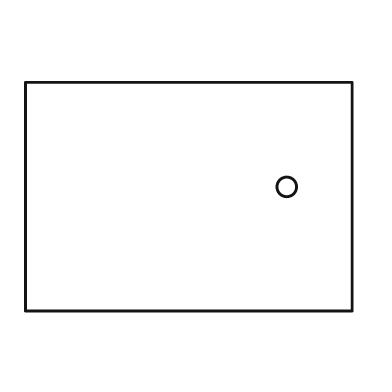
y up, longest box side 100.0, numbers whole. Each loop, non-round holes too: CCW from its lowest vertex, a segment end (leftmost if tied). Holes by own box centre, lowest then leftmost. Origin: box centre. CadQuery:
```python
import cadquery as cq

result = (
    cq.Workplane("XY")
    .moveTo(-50.0, -35.0)
    .lineTo(50.0, -35.0)
    .lineTo(50.0, 35.0)
    .lineTo(-50.0, 35.0)
    .close()
    .moveTo(30.0, 3.0)
    .circle(3.0)
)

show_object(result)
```